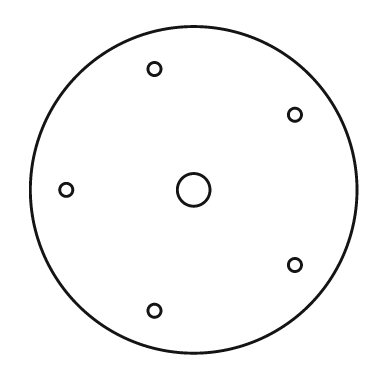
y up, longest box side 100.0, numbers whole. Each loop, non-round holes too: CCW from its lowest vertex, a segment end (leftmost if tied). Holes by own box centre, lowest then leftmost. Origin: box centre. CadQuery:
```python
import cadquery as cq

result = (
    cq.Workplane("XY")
    .moveTo(0.0, 0.0)
    .circle(50.0)
    .moveTo(-12.0, -37.0)
    .circle(2.0)
    .moveTo(31.0, -23.0)
    .circle(2.0)
    .moveTo(-39.0, 0.0)
    .circle(2.0)
    .moveTo(0.0, 0.0)
    .circle(5.0)
    .moveTo(31.0, 23.0)
    .circle(2.0)
    .moveTo(-12.0, 37.0)
    .circle(2.0)
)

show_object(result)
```